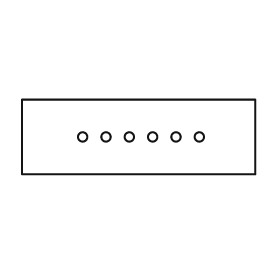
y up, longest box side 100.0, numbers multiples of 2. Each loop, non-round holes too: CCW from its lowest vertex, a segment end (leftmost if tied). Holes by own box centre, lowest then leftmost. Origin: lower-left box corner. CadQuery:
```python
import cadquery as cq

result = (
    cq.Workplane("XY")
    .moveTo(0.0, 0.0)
    .lineTo(100.0, 0.0)
    .lineTo(100.0, 32.0)
    .lineTo(0.0, 32.0)
    .close()
    .moveTo(26.0, 16.0)
    .circle(2.0)
    .moveTo(36.0, 16.0)
    .circle(2.0)
    .moveTo(46.0, 16.0)
    .circle(2.0)
    .moveTo(56.0, 16.0)
    .circle(2.0)
    .moveTo(66.0, 16.0)
    .circle(2.0)
    .moveTo(76.0, 16.0)
    .circle(2.0)
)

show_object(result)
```